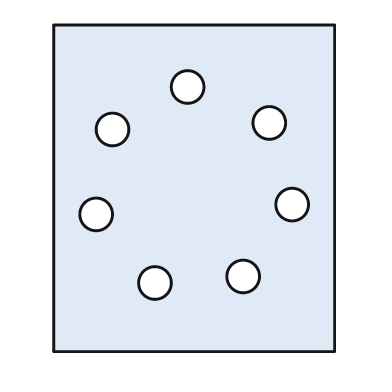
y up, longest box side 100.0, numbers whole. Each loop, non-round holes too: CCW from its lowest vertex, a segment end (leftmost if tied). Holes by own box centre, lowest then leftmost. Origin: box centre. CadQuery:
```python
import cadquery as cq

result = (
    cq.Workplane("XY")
    .moveTo(-43.0, -50.0)
    .lineTo(43.0, -50.0)
    .lineTo(43.0, 50.0)
    .lineTo(-43.0, 50.0)
    .close()
    .moveTo(-12.0, -29.0)
    .circle(5.0)
    .moveTo(15.0, -27.0)
    .circle(5.0)
    .moveTo(-30.0, -8.0)
    .circle(5.0)
    .moveTo(30.0, -5.0)
    .circle(5.0)
    .moveTo(-25.0, 18.0)
    .circle(5.0)
    .moveTo(23.0, 20.0)
    .circle(5.0)
    .moveTo(-2.0, 31.0)
    .circle(5.0)
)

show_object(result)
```